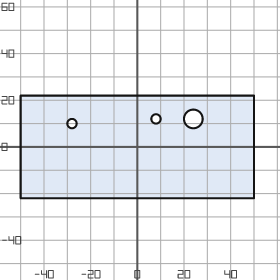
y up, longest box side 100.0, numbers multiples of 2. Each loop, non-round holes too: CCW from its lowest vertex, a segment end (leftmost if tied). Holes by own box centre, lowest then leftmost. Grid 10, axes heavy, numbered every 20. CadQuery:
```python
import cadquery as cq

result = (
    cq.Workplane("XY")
    .moveTo(-50.0, -22.0)
    .lineTo(50.0, -22.0)
    .lineTo(50.0, 22.0)
    .lineTo(-50.0, 22.0)
    .close()
    .moveTo(-28.0, 10.0)
    .circle(2.0)
    .moveTo(8.0, 12.0)
    .circle(2.0)
    .moveTo(24.0, 12.0)
    .circle(4.0)
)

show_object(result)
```